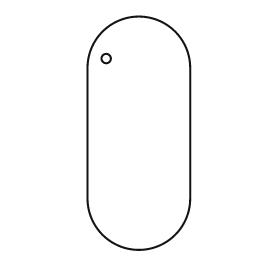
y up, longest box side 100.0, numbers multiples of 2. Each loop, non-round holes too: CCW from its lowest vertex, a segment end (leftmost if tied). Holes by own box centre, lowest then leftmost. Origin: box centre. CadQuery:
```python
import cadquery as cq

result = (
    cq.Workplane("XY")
    .moveTo(-22.0, -28.0)
    .threePointArc((0.0, -50.0), (22.0, -28.0))
    .lineTo(22.0, 28.0)
    .threePointArc((0.0, 50.0), (-22.0, 28.0))
    .close()
    .moveTo(-14.0, 32.0)
    .circle(2.0)
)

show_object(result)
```